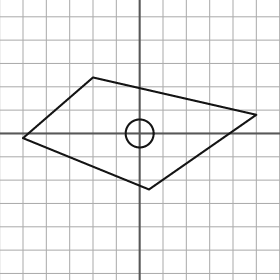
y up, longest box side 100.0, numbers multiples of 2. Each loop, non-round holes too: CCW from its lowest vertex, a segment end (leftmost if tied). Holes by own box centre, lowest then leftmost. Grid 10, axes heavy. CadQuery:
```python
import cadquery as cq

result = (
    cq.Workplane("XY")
    .moveTo(4.0, -24.0)
    .lineTo(50.0, 8.0)
    .lineTo(-20.0, 24.0)
    .lineTo(-50.0, -2.0)
    .close()
    .moveTo(0.0, 0.0)
    .circle(6.0)
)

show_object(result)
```